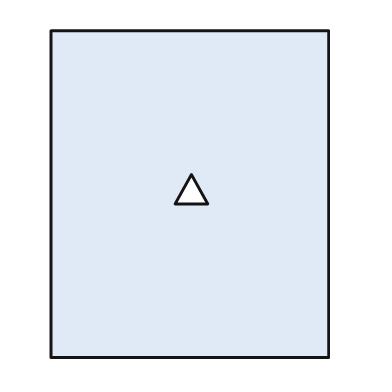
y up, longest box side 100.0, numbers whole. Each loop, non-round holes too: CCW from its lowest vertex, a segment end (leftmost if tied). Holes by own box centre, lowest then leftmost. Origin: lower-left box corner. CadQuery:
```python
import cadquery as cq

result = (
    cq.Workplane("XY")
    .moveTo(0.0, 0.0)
    .lineTo(85.0, 0.0)
    .lineTo(85.0, 100.0)
    .lineTo(0.0, 100.0)
    .close()
    .moveTo(38.0, 47.0)
    .lineTo(48.0, 47.0)
    .lineTo(43.0, 56.0)
    .close()
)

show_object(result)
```